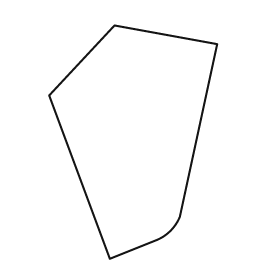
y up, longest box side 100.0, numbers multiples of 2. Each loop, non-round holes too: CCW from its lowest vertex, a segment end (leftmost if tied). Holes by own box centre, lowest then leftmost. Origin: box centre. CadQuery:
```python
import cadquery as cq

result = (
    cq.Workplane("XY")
    .moveTo(-10.0, -50.0)
    .lineTo(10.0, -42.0)
    .threePointArc((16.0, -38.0), (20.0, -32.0))
    .lineTo(36.0, 42.0)
    .lineTo(-8.0, 50.0)
    .lineTo(-36.0, 20.0)
    .close()
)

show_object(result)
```